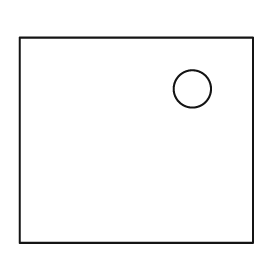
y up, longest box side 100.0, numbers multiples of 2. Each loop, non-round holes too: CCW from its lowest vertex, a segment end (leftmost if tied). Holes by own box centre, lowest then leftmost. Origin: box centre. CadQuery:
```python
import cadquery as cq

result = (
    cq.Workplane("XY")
    .moveTo(-50.0, -44.0)
    .lineTo(50.0, -44.0)
    .lineTo(50.0, 44.0)
    .lineTo(-50.0, 44.0)
    .close()
    .moveTo(24.0, 22.0)
    .circle(8.0)
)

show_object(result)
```